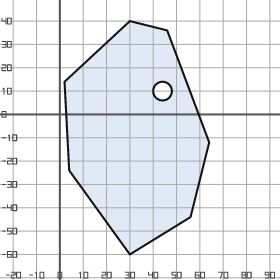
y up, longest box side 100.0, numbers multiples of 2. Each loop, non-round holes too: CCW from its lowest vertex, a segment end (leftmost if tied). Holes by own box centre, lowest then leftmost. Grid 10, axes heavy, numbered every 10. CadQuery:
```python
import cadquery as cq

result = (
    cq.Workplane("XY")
    .moveTo(30.0, -60.0)
    .lineTo(56.0, -44.0)
    .lineTo(64.0, -12.0)
    .lineTo(46.0, 36.0)
    .lineTo(30.0, 40.0)
    .lineTo(2.0, 14.0)
    .lineTo(4.0, -24.0)
    .close()
    .moveTo(44.0, 10.0)
    .circle(4.0)
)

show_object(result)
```